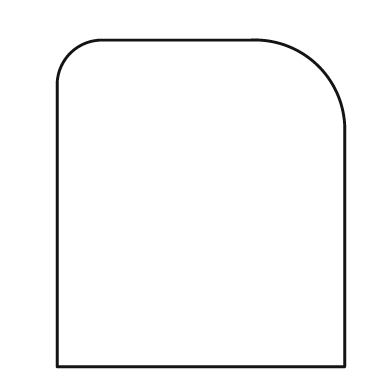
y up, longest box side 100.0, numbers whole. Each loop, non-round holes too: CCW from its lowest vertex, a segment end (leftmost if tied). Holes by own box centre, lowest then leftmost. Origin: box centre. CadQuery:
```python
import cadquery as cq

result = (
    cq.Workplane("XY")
    .moveTo(-44.0, -50.0)
    .lineTo(44.0, -50.0)
    .lineTo(44.0, 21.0)
    .threePointArc((36.0, 42.0), (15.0, 50.0))
    .lineTo(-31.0, 50.0)
    .threePointArc((-40.0, 46.0), (-44.0, 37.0))
    .close()
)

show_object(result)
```